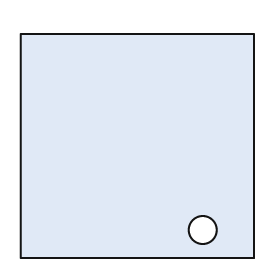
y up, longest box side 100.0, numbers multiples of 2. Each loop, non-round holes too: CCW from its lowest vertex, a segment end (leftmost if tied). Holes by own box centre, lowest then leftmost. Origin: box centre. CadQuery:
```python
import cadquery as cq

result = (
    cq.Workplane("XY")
    .moveTo(-50.0, -48.0)
    .lineTo(50.0, -48.0)
    .lineTo(50.0, 48.0)
    .lineTo(-50.0, 48.0)
    .close()
    .moveTo(28.0, -36.0)
    .circle(6.0)
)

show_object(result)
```